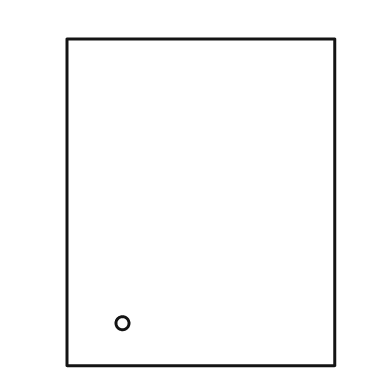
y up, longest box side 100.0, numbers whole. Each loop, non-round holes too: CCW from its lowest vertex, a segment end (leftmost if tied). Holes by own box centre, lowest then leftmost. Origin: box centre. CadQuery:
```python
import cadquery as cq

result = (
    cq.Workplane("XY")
    .moveTo(-41.0, -50.0)
    .lineTo(41.0, -50.0)
    .lineTo(41.0, 50.0)
    .lineTo(-41.0, 50.0)
    .close()
    .moveTo(-24.0, -37.0)
    .circle(2.0)
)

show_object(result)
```